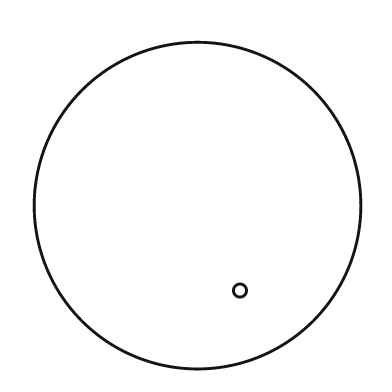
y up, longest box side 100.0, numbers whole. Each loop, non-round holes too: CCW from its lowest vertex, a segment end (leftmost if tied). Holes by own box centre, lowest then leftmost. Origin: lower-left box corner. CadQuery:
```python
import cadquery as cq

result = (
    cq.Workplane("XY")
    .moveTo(50.0, 50.0)
    .circle(50.0)
    .moveTo(63.0, 24.0)
    .circle(2.0)
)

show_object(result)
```